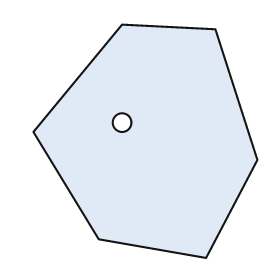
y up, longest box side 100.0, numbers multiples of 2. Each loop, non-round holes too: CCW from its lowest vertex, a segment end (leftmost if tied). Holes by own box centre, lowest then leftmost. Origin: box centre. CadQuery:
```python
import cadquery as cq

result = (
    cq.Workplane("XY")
    .moveTo(26.0, -50.0)
    .lineTo(48.0, -8.0)
    .lineTo(30.0, 48.0)
    .lineTo(-10.0, 50.0)
    .lineTo(-48.0, 4.0)
    .lineTo(-20.0, -42.0)
    .close()
    .moveTo(-10.0, 8.0)
    .circle(4.0)
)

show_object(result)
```